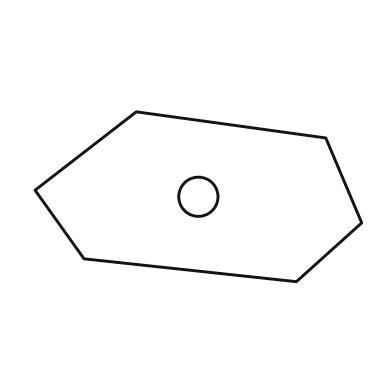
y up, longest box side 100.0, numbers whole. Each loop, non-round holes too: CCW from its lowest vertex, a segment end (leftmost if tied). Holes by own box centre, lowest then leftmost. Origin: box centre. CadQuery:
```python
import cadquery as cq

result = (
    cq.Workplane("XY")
    .moveTo(30.0, -26.0)
    .lineTo(50.0, -8.0)
    .lineTo(39.0, 18.0)
    .lineTo(-19.0, 26.0)
    .lineTo(-50.0, 2.0)
    .lineTo(-35.0, -19.0)
    .close()
    .moveTo(0.0, 0.0)
    .circle(6.0)
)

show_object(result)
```